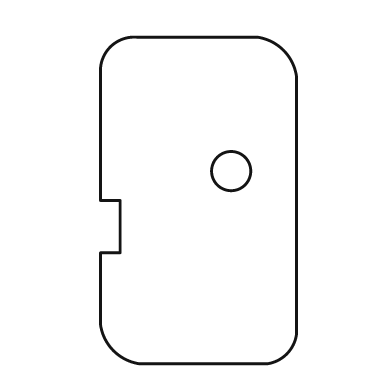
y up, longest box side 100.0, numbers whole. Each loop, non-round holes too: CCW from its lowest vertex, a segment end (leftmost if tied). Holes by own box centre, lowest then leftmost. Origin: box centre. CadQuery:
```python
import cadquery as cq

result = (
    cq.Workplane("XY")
    .moveTo(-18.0, -50.0)
    .lineTo(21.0, -50.0)
    .threePointArc((27.0, -47.0), (30.0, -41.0))
    .lineTo(30.0, 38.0)
    .threePointArc((26.0, 46.0), (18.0, 50.0))
    .lineTo(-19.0, 50.0)
    .threePointArc((-27.0, 47.0), (-30.0, 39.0))
    .lineTo(-30.0, 0.0)
    .lineTo(-24.0, 0.0)
    .lineTo(-24.0, -16.0)
    .lineTo(-30.0, -16.0)
    .lineTo(-30.0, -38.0)
    .threePointArc((-26.0, -46.0), (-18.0, -50.0))
    .close()
    .moveTo(10.0, 9.0)
    .circle(6.0)
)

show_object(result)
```